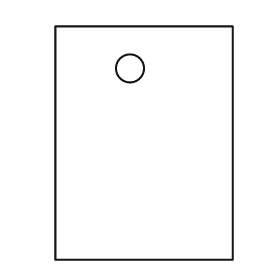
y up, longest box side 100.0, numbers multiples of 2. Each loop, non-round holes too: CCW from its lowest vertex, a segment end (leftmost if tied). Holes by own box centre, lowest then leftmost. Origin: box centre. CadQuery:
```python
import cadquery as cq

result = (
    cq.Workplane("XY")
    .moveTo(-38.0, -50.0)
    .lineTo(38.0, -50.0)
    .lineTo(38.0, 50.0)
    .lineTo(-38.0, 50.0)
    .close()
    .moveTo(-6.0, 32.0)
    .circle(6.0)
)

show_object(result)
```